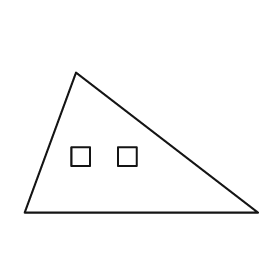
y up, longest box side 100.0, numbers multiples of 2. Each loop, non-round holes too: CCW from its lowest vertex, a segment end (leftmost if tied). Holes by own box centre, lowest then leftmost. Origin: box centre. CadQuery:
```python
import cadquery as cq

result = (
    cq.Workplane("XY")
    .moveTo(-50.0, -30.0)
    .lineTo(50.0, -30.0)
    .lineTo(-28.0, 30.0)
    .close()
    .moveTo(-30.0, -10.0)
    .lineTo(-22.0, -10.0)
    .lineTo(-22.0, -2.0)
    .lineTo(-30.0, -2.0)
    .close()
    .moveTo(-10.0, -10.0)
    .lineTo(-2.0, -10.0)
    .lineTo(-2.0, -2.0)
    .lineTo(-10.0, -2.0)
    .close()
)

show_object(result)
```